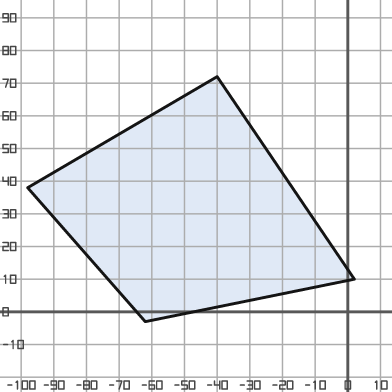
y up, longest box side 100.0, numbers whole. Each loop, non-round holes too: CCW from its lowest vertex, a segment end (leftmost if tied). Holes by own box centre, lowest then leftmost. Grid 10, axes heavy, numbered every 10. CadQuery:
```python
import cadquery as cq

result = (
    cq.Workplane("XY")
    .moveTo(-62.0, -3.0)
    .lineTo(2.0, 10.0)
    .lineTo(-40.0, 72.0)
    .lineTo(-98.0, 38.0)
    .close()
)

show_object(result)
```